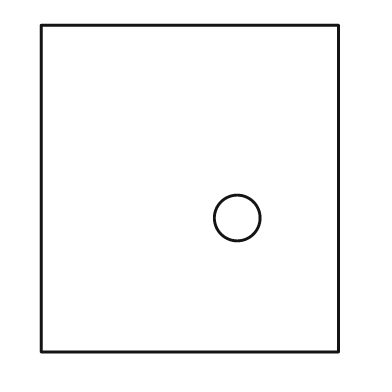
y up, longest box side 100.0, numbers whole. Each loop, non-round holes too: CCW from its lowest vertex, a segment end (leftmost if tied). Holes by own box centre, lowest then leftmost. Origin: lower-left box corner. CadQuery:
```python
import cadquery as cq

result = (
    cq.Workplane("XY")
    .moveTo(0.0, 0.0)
    .lineTo(91.0, 0.0)
    .lineTo(91.0, 100.0)
    .lineTo(0.0, 100.0)
    .close()
    .moveTo(60.0, 41.0)
    .circle(7.0)
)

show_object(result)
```